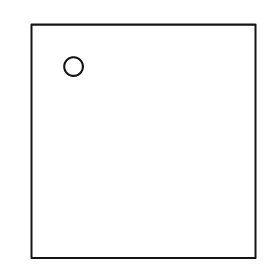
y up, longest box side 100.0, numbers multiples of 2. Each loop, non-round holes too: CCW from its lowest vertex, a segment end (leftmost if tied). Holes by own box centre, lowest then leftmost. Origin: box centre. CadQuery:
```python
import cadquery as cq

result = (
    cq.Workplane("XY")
    .moveTo(-48.0, -50.0)
    .lineTo(48.0, -50.0)
    .lineTo(48.0, 50.0)
    .lineTo(-48.0, 50.0)
    .close()
    .moveTo(-30.0, 32.0)
    .circle(4.0)
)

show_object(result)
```